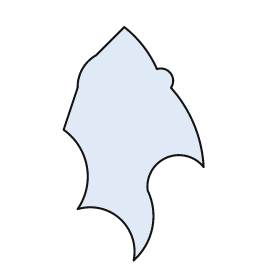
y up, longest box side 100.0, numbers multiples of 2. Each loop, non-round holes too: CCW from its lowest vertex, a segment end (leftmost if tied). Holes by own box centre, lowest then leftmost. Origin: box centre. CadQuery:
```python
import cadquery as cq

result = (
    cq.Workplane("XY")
    .moveTo(0.0, -50.0)
    .threePointArc((8.0, -36.0), (6.0, -20.0))
    .threePointArc((14.0, -6.0), (30.0, -10.0))
    .threePointArc((26.0, 8.0), (16.0, 24.0))
    .threePointArc((16.0, 30.0), (10.0, 32.0))
    .threePointArc((4.0, 42.0), (-4.0, 50.0))
    .lineTo(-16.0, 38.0)
    .threePointArc((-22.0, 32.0), (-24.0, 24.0))
    .lineTo(-30.0, 6.0)
    .threePointArc((-20.0, -10.0), (-24.0, -28.0))
    .threePointArc((-6.0, -32.0), (0.0, -50.0))
    .close()
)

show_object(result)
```